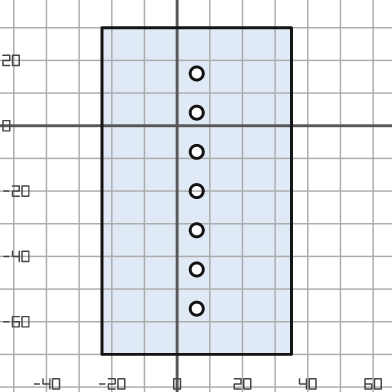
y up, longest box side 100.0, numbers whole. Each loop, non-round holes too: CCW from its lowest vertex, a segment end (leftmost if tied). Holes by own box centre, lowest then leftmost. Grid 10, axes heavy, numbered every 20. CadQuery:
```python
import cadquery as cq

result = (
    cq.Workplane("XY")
    .moveTo(-23.0, -70.0)
    .lineTo(35.0, -70.0)
    .lineTo(35.0, 30.0)
    .lineTo(-23.0, 30.0)
    .close()
    .moveTo(6.0, -56.0)
    .circle(2.0)
    .moveTo(6.0, -44.0)
    .circle(2.0)
    .moveTo(6.0, -32.0)
    .circle(2.0)
    .moveTo(6.0, -20.0)
    .circle(2.0)
    .moveTo(6.0, -8.0)
    .circle(2.0)
    .moveTo(6.0, 4.0)
    .circle(2.0)
    .moveTo(6.0, 16.0)
    .circle(2.0)
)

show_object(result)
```